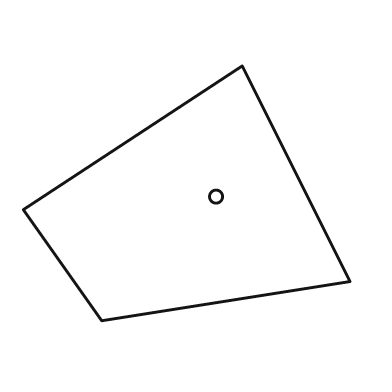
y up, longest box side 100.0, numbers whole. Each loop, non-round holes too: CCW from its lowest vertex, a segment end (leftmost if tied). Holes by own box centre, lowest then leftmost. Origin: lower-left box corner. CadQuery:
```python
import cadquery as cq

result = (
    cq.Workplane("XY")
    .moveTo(24.0, 0.0)
    .lineTo(100.0, 12.0)
    .lineTo(67.0, 78.0)
    .lineTo(0.0, 34.0)
    .close()
    .moveTo(59.0, 38.0)
    .circle(2.0)
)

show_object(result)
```